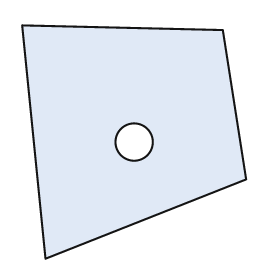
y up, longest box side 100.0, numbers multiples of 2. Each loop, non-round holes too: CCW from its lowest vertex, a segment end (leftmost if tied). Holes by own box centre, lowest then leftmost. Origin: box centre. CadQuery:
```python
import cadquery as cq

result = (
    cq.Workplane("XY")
    .moveTo(-38.0, -50.0)
    .lineTo(48.0, -16.0)
    .lineTo(38.0, 48.0)
    .lineTo(-48.0, 50.0)
    .close()
    .moveTo(0.0, 0.0)
    .circle(8.0)
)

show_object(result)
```